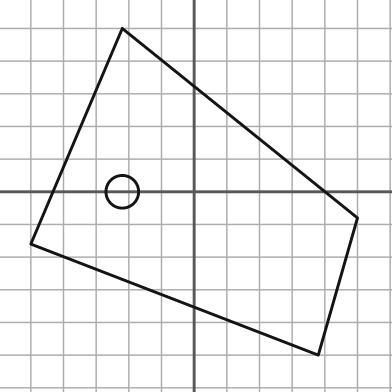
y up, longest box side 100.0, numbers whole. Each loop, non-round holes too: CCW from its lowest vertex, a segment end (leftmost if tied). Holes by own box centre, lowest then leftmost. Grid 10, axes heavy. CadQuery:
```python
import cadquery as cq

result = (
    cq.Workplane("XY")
    .moveTo(38.0, -50.0)
    .lineTo(50.0, -8.0)
    .lineTo(-22.0, 50.0)
    .lineTo(-50.0, -16.0)
    .close()
    .moveTo(-22.0, 0.0)
    .circle(5.0)
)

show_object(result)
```